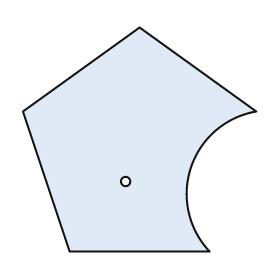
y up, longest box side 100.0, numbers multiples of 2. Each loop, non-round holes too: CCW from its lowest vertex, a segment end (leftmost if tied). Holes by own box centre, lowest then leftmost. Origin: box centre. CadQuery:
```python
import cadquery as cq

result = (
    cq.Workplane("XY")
    .moveTo(-30.0, -48.0)
    .lineTo(30.0, -48.0)
    .threePointArc((22.0, -12.0), (50.0, 12.0))
    .lineTo(0.0, 48.0)
    .lineTo(-50.0, 12.0)
    .close()
    .moveTo(-6.0, -18.0)
    .circle(2.0)
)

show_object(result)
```